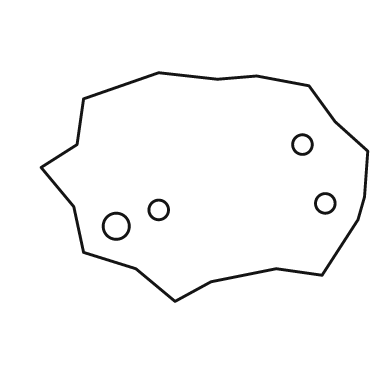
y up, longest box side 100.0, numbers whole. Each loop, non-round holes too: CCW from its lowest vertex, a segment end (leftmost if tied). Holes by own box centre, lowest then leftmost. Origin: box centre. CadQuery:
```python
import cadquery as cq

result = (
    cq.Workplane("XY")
    .moveTo(-9.0, -35.0)
    .lineTo(2.0, -29.0)
    .lineTo(22.0, -25.0)
    .lineTo(36.0, -27.0)
    .lineTo(47.0, -10.0)
    .lineTo(49.0, -3.0)
    .lineTo(50.0, 11.0)
    .lineTo(40.0, 20.0)
    .lineTo(32.0, 31.0)
    .lineTo(16.0, 34.0)
    .lineTo(4.0, 33.0)
    .lineTo(-14.0, 35.0)
    .lineTo(-37.0, 27.0)
    .lineTo(-39.0, 13.0)
    .lineTo(-50.0, 6.0)
    .lineTo(-40.0, -6.0)
    .lineTo(-37.0, -20.0)
    .lineTo(-21.0, -25.0)
    .close()
    .moveTo(-27.0, -12.0)
    .circle(4.0)
    .moveTo(-14.0, -7.0)
    .circle(3.0)
    .moveTo(37.0, -5.0)
    .circle(3.0)
    .moveTo(30.0, 13.0)
    .circle(3.0)
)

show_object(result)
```